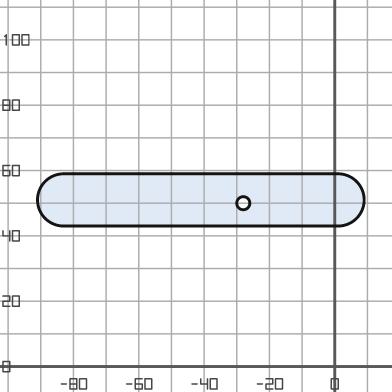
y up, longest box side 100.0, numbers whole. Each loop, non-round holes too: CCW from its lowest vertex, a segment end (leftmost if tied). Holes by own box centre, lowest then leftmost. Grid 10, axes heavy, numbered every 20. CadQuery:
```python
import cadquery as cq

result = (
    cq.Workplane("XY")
    .moveTo(-83.0, 43.0)
    .lineTo(1.0, 43.0)
    .threePointArc((9.0, 51.0), (1.0, 59.0))
    .lineTo(-83.0, 59.0)
    .threePointArc((-91.0, 51.0), (-83.0, 43.0))
    .close()
    .moveTo(-28.0, 50.0)
    .circle(2.0)
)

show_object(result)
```